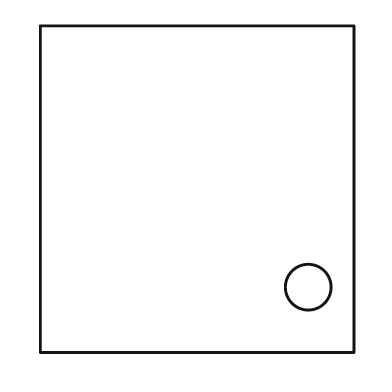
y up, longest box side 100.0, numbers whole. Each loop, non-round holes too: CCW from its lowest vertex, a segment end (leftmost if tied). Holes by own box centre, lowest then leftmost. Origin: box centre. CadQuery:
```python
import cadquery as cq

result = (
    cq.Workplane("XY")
    .moveTo(-48.0, -50.0)
    .lineTo(48.0, -50.0)
    .lineTo(48.0, 50.0)
    .lineTo(-48.0, 50.0)
    .close()
    .moveTo(34.0, -30.0)
    .circle(7.0)
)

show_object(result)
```